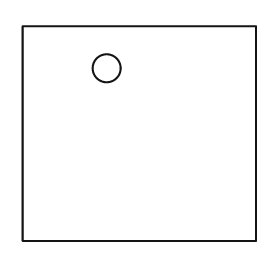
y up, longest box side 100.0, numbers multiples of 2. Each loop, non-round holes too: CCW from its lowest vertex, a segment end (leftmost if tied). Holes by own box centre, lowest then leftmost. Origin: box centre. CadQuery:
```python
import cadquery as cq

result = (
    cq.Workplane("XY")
    .moveTo(-50.0, -46.0)
    .lineTo(50.0, -46.0)
    .lineTo(50.0, 46.0)
    .lineTo(-50.0, 46.0)
    .close()
    .moveTo(-14.0, 28.0)
    .circle(6.0)
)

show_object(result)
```